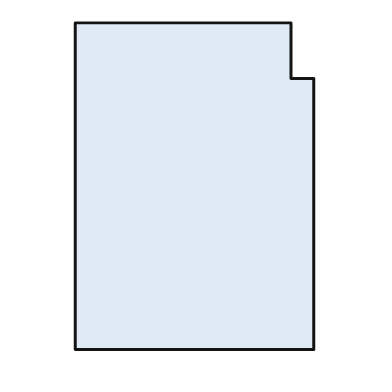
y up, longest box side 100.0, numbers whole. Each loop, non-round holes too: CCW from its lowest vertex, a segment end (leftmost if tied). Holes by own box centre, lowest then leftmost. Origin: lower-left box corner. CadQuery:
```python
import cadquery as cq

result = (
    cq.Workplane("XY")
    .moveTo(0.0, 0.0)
    .lineTo(73.0, 0.0)
    .lineTo(73.0, 83.0)
    .lineTo(66.0, 83.0)
    .lineTo(66.0, 100.0)
    .lineTo(0.0, 100.0)
    .close()
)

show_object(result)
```